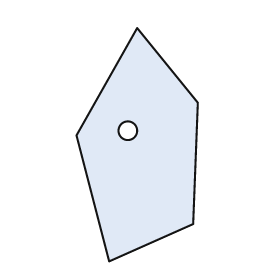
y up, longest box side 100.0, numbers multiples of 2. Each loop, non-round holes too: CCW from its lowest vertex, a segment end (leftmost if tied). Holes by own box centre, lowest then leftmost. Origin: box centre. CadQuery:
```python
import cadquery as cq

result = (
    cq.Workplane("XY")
    .moveTo(-12.0, -50.0)
    .lineTo(24.0, -34.0)
    .lineTo(26.0, 18.0)
    .lineTo(0.0, 50.0)
    .lineTo(-26.0, 4.0)
    .close()
    .moveTo(-4.0, 6.0)
    .circle(4.0)
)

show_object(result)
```